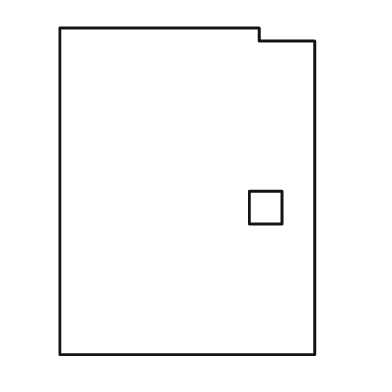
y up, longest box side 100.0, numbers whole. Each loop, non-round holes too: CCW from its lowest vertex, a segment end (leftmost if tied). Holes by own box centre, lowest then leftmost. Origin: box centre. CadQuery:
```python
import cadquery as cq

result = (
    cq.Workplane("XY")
    .moveTo(-39.0, -50.0)
    .lineTo(39.0, -50.0)
    .lineTo(39.0, 46.0)
    .lineTo(22.0, 46.0)
    .lineTo(22.0, 50.0)
    .lineTo(-39.0, 50.0)
    .close()
    .moveTo(19.0, -10.0)
    .lineTo(29.0, -10.0)
    .lineTo(29.0, 0.0)
    .lineTo(19.0, 0.0)
    .close()
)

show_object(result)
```